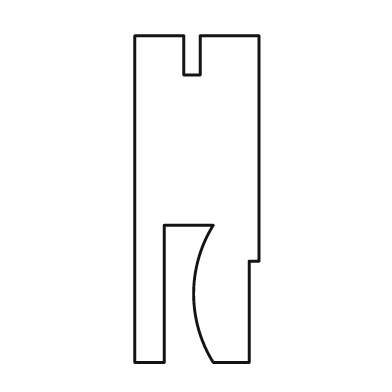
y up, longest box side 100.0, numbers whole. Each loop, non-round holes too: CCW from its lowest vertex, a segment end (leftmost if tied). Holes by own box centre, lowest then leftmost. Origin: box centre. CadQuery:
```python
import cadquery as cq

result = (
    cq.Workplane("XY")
    .moveTo(-19.0, -50.0)
    .lineTo(-10.0, -50.0)
    .lineTo(-10.0, -8.0)
    .lineTo(5.0, -8.0)
    .threePointArc((-1.0, -29.0), (5.0, -50.0))
    .lineTo(16.0, -50.0)
    .lineTo(16.0, -19.0)
    .lineTo(19.0, -19.0)
    .lineTo(19.0, 50.0)
    .lineTo(1.0, 50.0)
    .lineTo(1.0, 38.0)
    .lineTo(-4.0, 38.0)
    .lineTo(-4.0, 50.0)
    .lineTo(-19.0, 50.0)
    .close()
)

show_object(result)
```